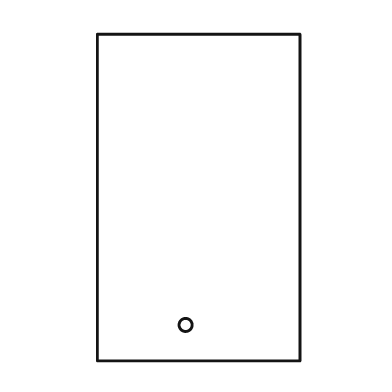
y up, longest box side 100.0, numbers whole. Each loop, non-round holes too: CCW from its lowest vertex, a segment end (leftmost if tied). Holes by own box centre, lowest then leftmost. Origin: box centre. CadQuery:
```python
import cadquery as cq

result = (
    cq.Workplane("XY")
    .moveTo(-31.0, -50.0)
    .lineTo(31.0, -50.0)
    .lineTo(31.0, 50.0)
    .lineTo(-31.0, 50.0)
    .close()
    .moveTo(-4.0, -39.0)
    .circle(2.0)
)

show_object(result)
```